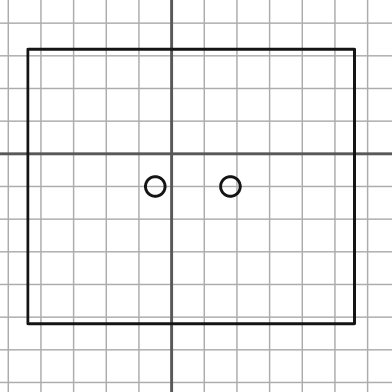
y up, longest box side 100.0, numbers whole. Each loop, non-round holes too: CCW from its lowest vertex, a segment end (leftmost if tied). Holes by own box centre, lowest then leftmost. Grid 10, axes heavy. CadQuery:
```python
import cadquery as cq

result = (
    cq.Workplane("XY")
    .moveTo(-44.0, -52.0)
    .lineTo(56.0, -52.0)
    .lineTo(56.0, 32.0)
    .lineTo(-44.0, 32.0)
    .close()
    .moveTo(-5.0, -10.0)
    .circle(3.0)
    .moveTo(18.0, -10.0)
    .circle(3.0)
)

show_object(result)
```